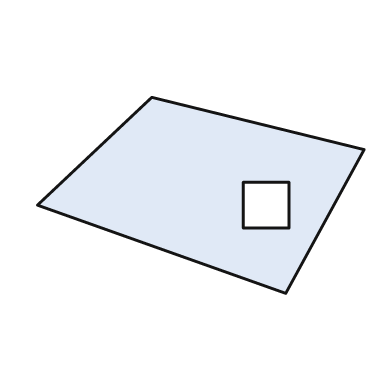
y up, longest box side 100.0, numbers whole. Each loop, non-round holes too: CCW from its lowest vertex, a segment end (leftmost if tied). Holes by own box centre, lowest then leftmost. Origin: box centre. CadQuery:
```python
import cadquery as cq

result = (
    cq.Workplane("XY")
    .moveTo(26.0, -30.0)
    .lineTo(50.0, 14.0)
    .lineTo(-15.0, 30.0)
    .lineTo(-50.0, -3.0)
    .close()
    .moveTo(13.0, -10.0)
    .lineTo(27.0, -10.0)
    .lineTo(27.0, 4.0)
    .lineTo(13.0, 4.0)
    .close()
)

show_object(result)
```